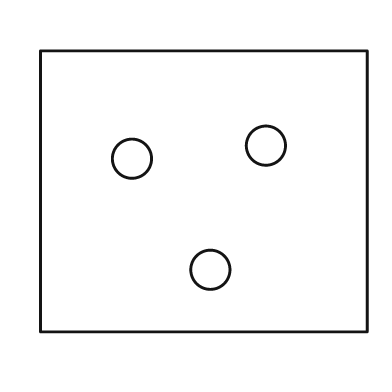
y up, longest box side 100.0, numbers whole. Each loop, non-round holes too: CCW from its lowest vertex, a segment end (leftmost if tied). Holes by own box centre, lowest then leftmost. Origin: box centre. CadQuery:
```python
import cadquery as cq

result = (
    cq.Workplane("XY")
    .moveTo(-50.0, -43.0)
    .lineTo(50.0, -43.0)
    .lineTo(50.0, 43.0)
    .lineTo(-50.0, 43.0)
    .close()
    .moveTo(2.0, -24.0)
    .circle(6.0)
    .moveTo(-22.0, 10.0)
    .circle(6.0)
    .moveTo(19.0, 14.0)
    .circle(6.0)
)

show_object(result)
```